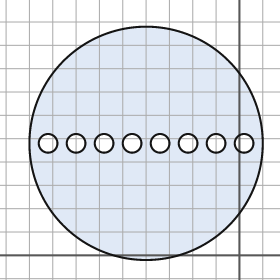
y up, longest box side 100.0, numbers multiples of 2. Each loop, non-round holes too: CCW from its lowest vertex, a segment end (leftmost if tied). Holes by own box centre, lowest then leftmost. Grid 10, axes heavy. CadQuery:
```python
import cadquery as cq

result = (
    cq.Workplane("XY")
    .moveTo(-40.0, 48.0)
    .circle(50.0)
    .moveTo(-82.0, 48.0)
    .circle(4.0)
    .moveTo(-70.0, 48.0)
    .circle(4.0)
    .moveTo(-58.0, 48.0)
    .circle(4.0)
    .moveTo(-46.0, 48.0)
    .circle(4.0)
    .moveTo(-34.0, 48.0)
    .circle(4.0)
    .moveTo(-22.0, 48.0)
    .circle(4.0)
    .moveTo(-10.0, 48.0)
    .circle(4.0)
    .moveTo(2.0, 48.0)
    .circle(4.0)
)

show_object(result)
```